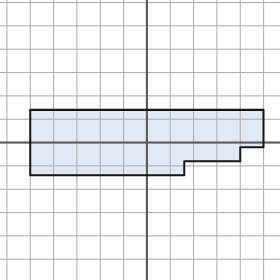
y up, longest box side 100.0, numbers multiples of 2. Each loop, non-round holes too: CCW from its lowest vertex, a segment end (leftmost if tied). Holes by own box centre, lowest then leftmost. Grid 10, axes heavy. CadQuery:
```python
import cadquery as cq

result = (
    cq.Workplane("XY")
    .moveTo(-50.0, -14.0)
    .lineTo(16.0, -14.0)
    .lineTo(16.0, -8.0)
    .lineTo(40.0, -8.0)
    .lineTo(40.0, -2.0)
    .lineTo(50.0, -2.0)
    .lineTo(50.0, 14.0)
    .lineTo(-50.0, 14.0)
    .close()
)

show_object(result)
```